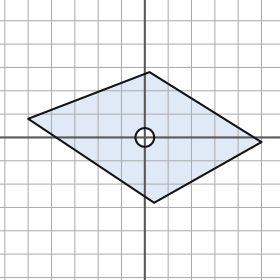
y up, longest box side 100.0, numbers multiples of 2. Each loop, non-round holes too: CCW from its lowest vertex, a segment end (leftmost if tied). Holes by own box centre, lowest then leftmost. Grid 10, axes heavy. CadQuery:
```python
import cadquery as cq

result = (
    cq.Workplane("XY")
    .moveTo(4.0, -28.0)
    .lineTo(50.0, -2.0)
    .lineTo(2.0, 28.0)
    .lineTo(-50.0, 8.0)
    .close()
    .moveTo(0.0, 0.0)
    .circle(4.0)
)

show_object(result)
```